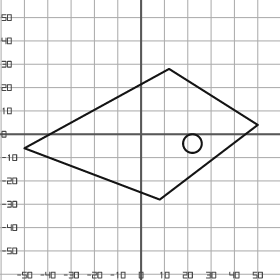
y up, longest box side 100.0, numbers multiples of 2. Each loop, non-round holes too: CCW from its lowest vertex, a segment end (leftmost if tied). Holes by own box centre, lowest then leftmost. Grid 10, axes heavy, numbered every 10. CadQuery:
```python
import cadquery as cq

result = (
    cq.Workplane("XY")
    .moveTo(8.0, -28.0)
    .lineTo(50.0, 4.0)
    .lineTo(12.0, 28.0)
    .lineTo(-50.0, -6.0)
    .close()
    .moveTo(22.0, -4.0)
    .circle(4.0)
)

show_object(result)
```